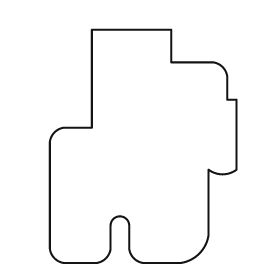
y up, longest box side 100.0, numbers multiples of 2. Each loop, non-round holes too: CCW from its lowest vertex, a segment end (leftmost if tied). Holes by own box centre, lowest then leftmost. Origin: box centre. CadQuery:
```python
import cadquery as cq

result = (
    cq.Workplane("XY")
    .moveTo(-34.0, -50.0)
    .lineTo(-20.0, -50.0)
    .threePointArc((-16.0, -48.0), (-14.0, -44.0))
    .lineTo(-14.0, -34.0)
    .threePointArc((-10.0, -30.0), (-6.0, -34.0))
    .lineTo(-6.0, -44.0)
    .threePointArc((-4.0, -48.0), (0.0, -50.0))
    .lineTo(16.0, -50.0)
    .threePointArc((24.0, -46.0), (28.0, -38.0))
    .lineTo(28.0, -10.0)
    .threePointArc((34.0, -12.0), (40.0, -10.0))
    .lineTo(40.0, 20.0)
    .lineTo(36.0, 20.0)
    .lineTo(36.0, 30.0)
    .threePointArc((34.0, 34.0), (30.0, 36.0))
    .lineTo(12.0, 36.0)
    .lineTo(12.0, 50.0)
    .lineTo(-22.0, 50.0)
    .lineTo(-22.0, 8.0)
    .lineTo(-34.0, 8.0)
    .threePointArc((-38.0, 6.0), (-40.0, 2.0))
    .lineTo(-40.0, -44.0)
    .threePointArc((-38.0, -48.0), (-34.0, -50.0))
    .close()
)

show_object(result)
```